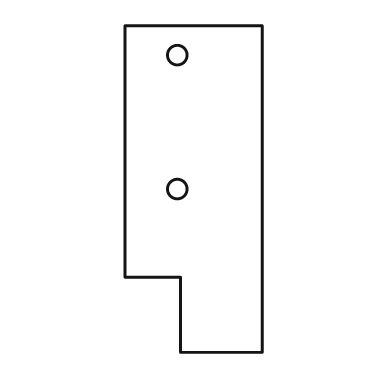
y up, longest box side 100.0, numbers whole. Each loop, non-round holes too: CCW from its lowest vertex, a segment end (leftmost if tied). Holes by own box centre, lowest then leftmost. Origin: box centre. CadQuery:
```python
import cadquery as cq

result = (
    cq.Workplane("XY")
    .moveTo(-4.0, -50.0)
    .lineTo(21.0, -50.0)
    .lineTo(21.0, 50.0)
    .lineTo(-21.0, 50.0)
    .lineTo(-21.0, -27.0)
    .lineTo(-4.0, -27.0)
    .close()
    .moveTo(-5.0, 0.0)
    .circle(3.0)
    .moveTo(-5.0, 41.0)
    .circle(3.0)
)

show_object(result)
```